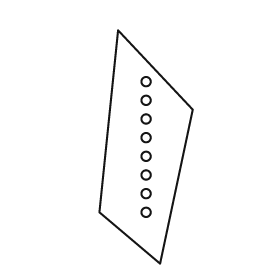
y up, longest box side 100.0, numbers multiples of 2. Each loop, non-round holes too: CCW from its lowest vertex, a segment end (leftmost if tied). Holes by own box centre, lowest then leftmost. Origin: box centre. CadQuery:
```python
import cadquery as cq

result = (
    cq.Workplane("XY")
    .moveTo(6.0, -50.0)
    .lineTo(20.0, 16.0)
    .lineTo(-12.0, 50.0)
    .lineTo(-20.0, -28.0)
    .close()
    .moveTo(0.0, -28.0)
    .circle(2.0)
    .moveTo(0.0, -20.0)
    .circle(2.0)
    .moveTo(0.0, -12.0)
    .circle(2.0)
    .moveTo(0.0, -4.0)
    .circle(2.0)
    .moveTo(0.0, 4.0)
    .circle(2.0)
    .moveTo(0.0, 12.0)
    .circle(2.0)
    .moveTo(0.0, 20.0)
    .circle(2.0)
    .moveTo(0.0, 28.0)
    .circle(2.0)
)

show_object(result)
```